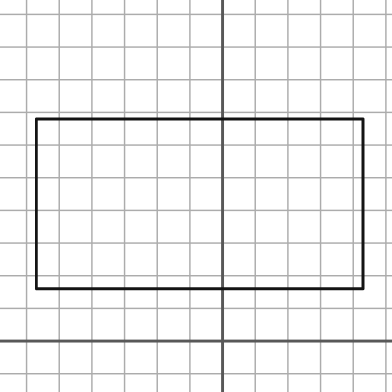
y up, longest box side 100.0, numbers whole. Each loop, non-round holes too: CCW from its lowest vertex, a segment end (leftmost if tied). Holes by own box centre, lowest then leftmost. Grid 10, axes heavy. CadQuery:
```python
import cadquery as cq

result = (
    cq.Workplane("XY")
    .moveTo(-57.0, 16.0)
    .lineTo(43.0, 16.0)
    .lineTo(43.0, 68.0)
    .lineTo(-57.0, 68.0)
    .close()
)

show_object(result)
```